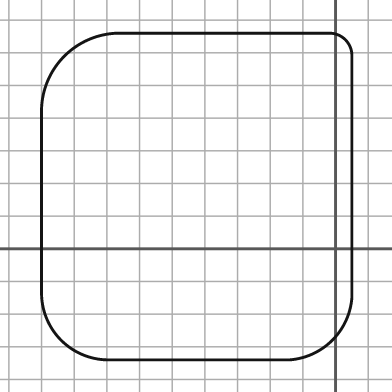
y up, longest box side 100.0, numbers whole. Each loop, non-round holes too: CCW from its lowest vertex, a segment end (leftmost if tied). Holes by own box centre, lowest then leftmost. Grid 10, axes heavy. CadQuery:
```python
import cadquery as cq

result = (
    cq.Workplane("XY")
    .moveTo(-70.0, -34.0)
    .lineTo(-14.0, -34.0)
    .threePointArc((-1.0, -28.0), (5.0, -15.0))
    .lineTo(5.0, 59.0)
    .threePointArc((3.0, 64.0), (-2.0, 66.0))
    .lineTo(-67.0, 66.0)
    .threePointArc((-83.0, 59.0), (-90.0, 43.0))
    .lineTo(-90.0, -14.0)
    .threePointArc((-84.0, -28.0), (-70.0, -34.0))
    .close()
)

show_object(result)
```